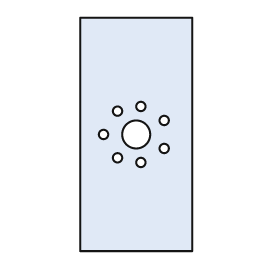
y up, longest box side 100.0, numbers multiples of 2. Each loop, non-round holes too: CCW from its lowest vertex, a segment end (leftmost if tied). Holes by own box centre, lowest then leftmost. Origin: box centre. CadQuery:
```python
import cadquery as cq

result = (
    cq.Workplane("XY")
    .moveTo(-24.0, -50.0)
    .lineTo(24.0, -50.0)
    .lineTo(24.0, 50.0)
    .lineTo(-24.0, 50.0)
    .close()
    .moveTo(2.0, -12.0)
    .circle(2.0)
    .moveTo(-8.0, -10.0)
    .circle(2.0)
    .moveTo(12.0, -6.0)
    .circle(2.0)
    .moveTo(-14.0, 0.0)
    .circle(2.0)
    .moveTo(0.0, 0.0)
    .circle(6.0)
    .moveTo(12.0, 6.0)
    .circle(2.0)
    .moveTo(-8.0, 10.0)
    .circle(2.0)
    .moveTo(2.0, 12.0)
    .circle(2.0)
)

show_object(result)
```